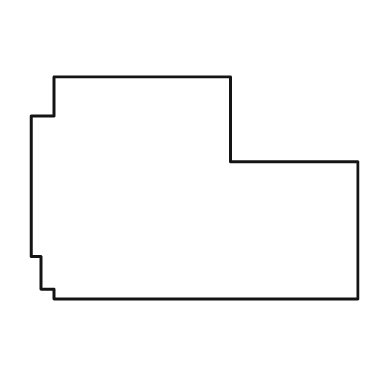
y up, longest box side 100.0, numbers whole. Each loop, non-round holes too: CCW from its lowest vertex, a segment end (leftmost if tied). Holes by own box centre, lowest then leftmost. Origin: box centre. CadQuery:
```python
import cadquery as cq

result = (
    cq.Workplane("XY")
    .moveTo(-43.0, -34.0)
    .lineTo(50.0, -34.0)
    .lineTo(50.0, 8.0)
    .lineTo(11.0, 8.0)
    .lineTo(11.0, 34.0)
    .lineTo(-43.0, 34.0)
    .lineTo(-43.0, 22.0)
    .lineTo(-50.0, 22.0)
    .lineTo(-50.0, -21.0)
    .lineTo(-47.0, -21.0)
    .lineTo(-47.0, -31.0)
    .lineTo(-43.0, -31.0)
    .close()
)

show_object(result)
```